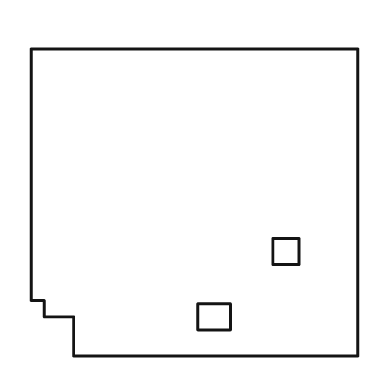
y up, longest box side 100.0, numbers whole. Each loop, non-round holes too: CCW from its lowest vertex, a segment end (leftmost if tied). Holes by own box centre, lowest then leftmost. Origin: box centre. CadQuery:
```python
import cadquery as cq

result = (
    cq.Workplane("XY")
    .moveTo(-37.0, -47.0)
    .lineTo(50.0, -47.0)
    .lineTo(50.0, 47.0)
    .lineTo(-50.0, 47.0)
    .lineTo(-50.0, -30.0)
    .lineTo(-46.0, -30.0)
    .lineTo(-46.0, -35.0)
    .lineTo(-37.0, -35.0)
    .close()
    .moveTo(1.0, -39.0)
    .lineTo(11.0, -39.0)
    .lineTo(11.0, -31.0)
    .lineTo(1.0, -31.0)
    .close()
    .moveTo(24.0, -19.0)
    .lineTo(32.0, -19.0)
    .lineTo(32.0, -11.0)
    .lineTo(24.0, -11.0)
    .close()
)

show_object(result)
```